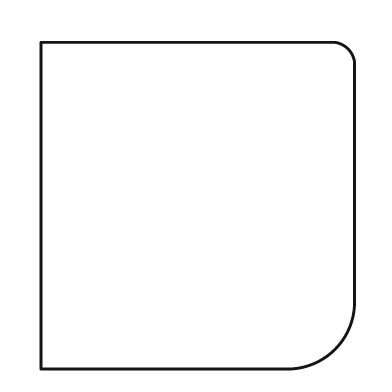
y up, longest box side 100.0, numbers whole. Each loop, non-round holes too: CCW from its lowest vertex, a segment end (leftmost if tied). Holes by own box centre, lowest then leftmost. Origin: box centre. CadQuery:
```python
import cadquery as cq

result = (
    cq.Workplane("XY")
    .moveTo(-48.0, -50.0)
    .lineTo(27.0, -50.0)
    .threePointArc((42.0, -44.0), (48.0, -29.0))
    .lineTo(48.0, 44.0)
    .threePointArc((46.0, 48.0), (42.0, 50.0))
    .lineTo(-48.0, 50.0)
    .close()
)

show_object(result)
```